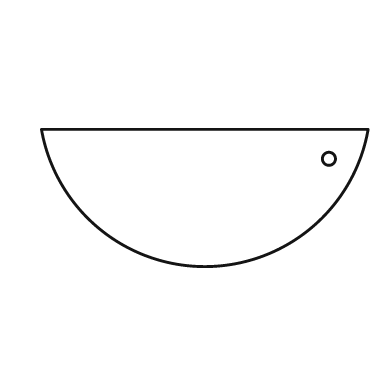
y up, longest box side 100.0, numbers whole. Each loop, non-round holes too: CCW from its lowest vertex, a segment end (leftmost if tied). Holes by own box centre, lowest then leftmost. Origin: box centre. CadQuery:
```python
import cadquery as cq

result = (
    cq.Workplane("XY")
    .moveTo(-50.0, 21.0)
    .threePointArc((0.0, -21.0), (50.0, 21.0))
    .close()
    .moveTo(38.0, 12.0)
    .circle(2.0)
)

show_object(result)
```